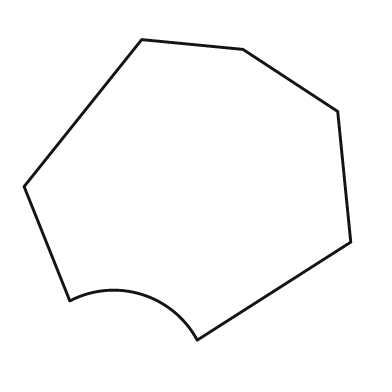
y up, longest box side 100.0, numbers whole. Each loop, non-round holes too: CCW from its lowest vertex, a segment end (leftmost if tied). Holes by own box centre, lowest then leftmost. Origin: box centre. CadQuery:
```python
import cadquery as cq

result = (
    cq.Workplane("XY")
    .moveTo(3.0, -46.0)
    .lineTo(50.0, -16.0)
    .lineTo(46.0, 24.0)
    .lineTo(17.0, 43.0)
    .lineTo(-14.0, 46.0)
    .lineTo(-50.0, 1.0)
    .lineTo(-36.0, -34.0)
    .threePointArc((-14.0, -32.0), (3.0, -46.0))
    .close()
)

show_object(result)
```